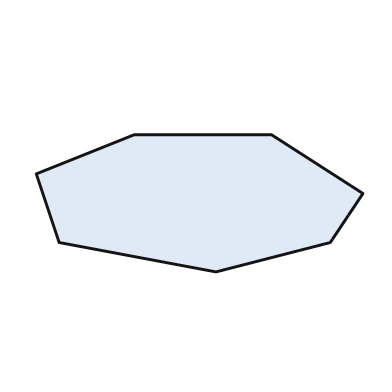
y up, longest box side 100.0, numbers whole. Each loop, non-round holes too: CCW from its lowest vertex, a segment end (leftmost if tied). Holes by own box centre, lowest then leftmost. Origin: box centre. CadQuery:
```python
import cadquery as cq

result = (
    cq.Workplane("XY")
    .moveTo(5.0, -21.0)
    .lineTo(40.0, -12.0)
    .lineTo(50.0, 3.0)
    .lineTo(22.0, 21.0)
    .lineTo(-20.0, 21.0)
    .lineTo(-50.0, 9.0)
    .lineTo(-43.0, -12.0)
    .close()
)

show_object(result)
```